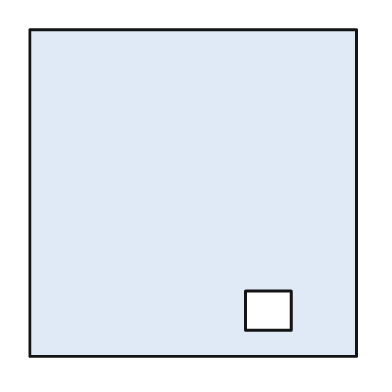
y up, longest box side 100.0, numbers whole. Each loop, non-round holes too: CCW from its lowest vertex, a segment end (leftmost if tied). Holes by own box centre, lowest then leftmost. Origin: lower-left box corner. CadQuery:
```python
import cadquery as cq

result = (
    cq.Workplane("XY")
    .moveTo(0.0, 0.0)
    .lineTo(100.0, 0.0)
    .lineTo(100.0, 100.0)
    .lineTo(0.0, 100.0)
    .close()
    .moveTo(66.0, 8.0)
    .lineTo(80.0, 8.0)
    .lineTo(80.0, 20.0)
    .lineTo(66.0, 20.0)
    .close()
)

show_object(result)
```